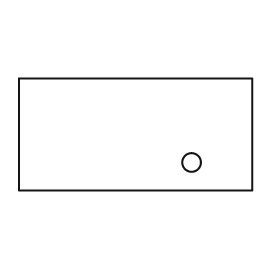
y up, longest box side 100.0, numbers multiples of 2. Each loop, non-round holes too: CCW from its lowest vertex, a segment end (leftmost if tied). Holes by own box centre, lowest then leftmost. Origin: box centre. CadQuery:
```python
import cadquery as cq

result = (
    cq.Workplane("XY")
    .moveTo(-50.0, -24.0)
    .lineTo(50.0, -24.0)
    .lineTo(50.0, 24.0)
    .lineTo(-50.0, 24.0)
    .close()
    .moveTo(24.0, -12.0)
    .circle(4.0)
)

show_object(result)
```